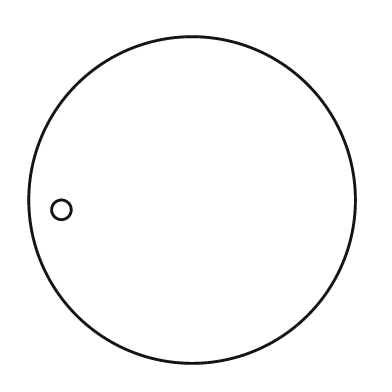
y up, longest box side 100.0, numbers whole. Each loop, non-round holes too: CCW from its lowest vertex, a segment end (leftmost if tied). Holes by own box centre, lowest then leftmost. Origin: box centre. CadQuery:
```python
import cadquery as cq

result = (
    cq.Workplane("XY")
    .moveTo(0.0, 0.0)
    .circle(50.0)
    .moveTo(-40.0, -3.0)
    .circle(3.0)
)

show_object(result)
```